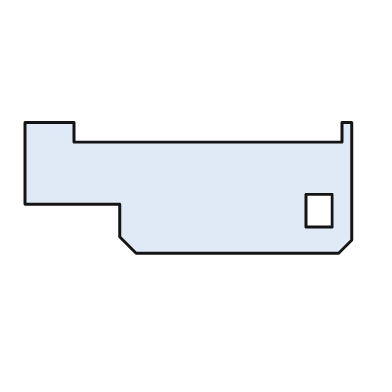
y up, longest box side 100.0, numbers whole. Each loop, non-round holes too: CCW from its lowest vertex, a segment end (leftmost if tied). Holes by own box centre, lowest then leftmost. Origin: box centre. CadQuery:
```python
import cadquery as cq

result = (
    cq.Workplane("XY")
    .moveTo(-16.0, -20.0)
    .lineTo(46.0, -20.0)
    .lineTo(50.0, -16.0)
    .lineTo(50.0, 20.0)
    .lineTo(47.0, 20.0)
    .lineTo(47.0, 14.0)
    .lineTo(-35.0, 14.0)
    .lineTo(-35.0, 20.0)
    .lineTo(-50.0, 20.0)
    .lineTo(-50.0, -5.0)
    .lineTo(-21.0, -5.0)
    .lineTo(-21.0, -15.0)
    .close()
    .moveTo(36.0, -12.0)
    .lineTo(44.0, -12.0)
    .lineTo(44.0, -2.0)
    .lineTo(36.0, -2.0)
    .close()
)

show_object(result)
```